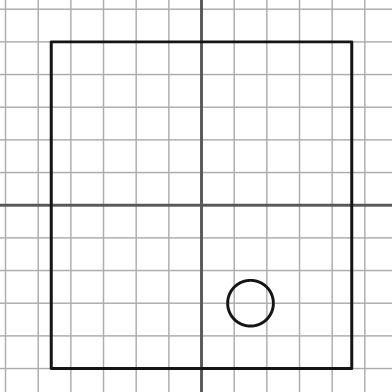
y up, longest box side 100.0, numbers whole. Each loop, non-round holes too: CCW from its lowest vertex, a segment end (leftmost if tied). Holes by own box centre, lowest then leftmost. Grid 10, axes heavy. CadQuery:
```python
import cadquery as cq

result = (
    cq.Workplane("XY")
    .moveTo(-46.0, -50.0)
    .lineTo(46.0, -50.0)
    .lineTo(46.0, 50.0)
    .lineTo(-46.0, 50.0)
    .close()
    .moveTo(15.0, -30.0)
    .circle(7.0)
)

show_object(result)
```